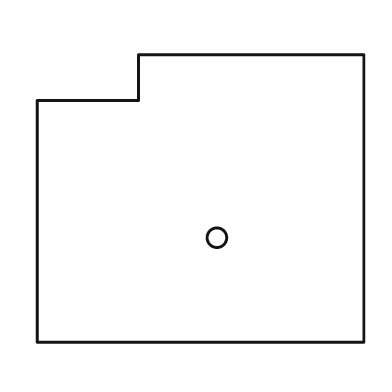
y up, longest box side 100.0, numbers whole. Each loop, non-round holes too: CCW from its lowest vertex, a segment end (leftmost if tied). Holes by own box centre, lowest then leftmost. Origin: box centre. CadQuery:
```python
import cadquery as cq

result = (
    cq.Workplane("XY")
    .moveTo(-50.0, -44.0)
    .lineTo(50.0, -44.0)
    .lineTo(50.0, 44.0)
    .lineTo(-19.0, 44.0)
    .lineTo(-19.0, 30.0)
    .lineTo(-50.0, 30.0)
    .close()
    .moveTo(5.0, -12.0)
    .circle(3.0)
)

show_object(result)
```